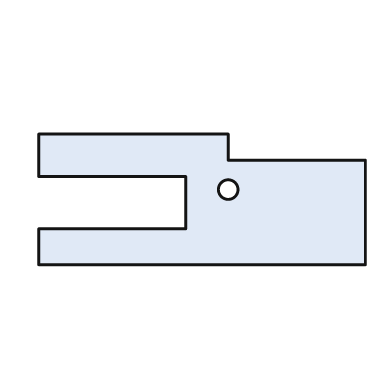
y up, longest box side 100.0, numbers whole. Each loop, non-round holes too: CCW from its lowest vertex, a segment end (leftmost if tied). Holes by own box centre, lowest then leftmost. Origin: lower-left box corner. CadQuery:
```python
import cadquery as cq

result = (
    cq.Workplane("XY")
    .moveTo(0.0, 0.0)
    .lineTo(100.0, 0.0)
    .lineTo(100.0, 32.0)
    .lineTo(58.0, 32.0)
    .lineTo(58.0, 40.0)
    .lineTo(0.0, 40.0)
    .lineTo(0.0, 27.0)
    .lineTo(45.0, 27.0)
    .lineTo(45.0, 11.0)
    .lineTo(0.0, 11.0)
    .close()
    .moveTo(58.0, 23.0)
    .circle(3.0)
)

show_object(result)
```